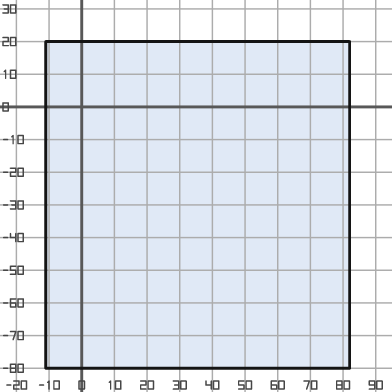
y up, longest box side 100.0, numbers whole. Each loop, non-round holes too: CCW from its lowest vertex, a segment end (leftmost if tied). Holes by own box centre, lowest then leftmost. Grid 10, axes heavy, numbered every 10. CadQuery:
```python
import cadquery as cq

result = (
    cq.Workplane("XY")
    .moveTo(-11.0, -80.0)
    .lineTo(82.0, -80.0)
    .lineTo(82.0, 20.0)
    .lineTo(-11.0, 20.0)
    .close()
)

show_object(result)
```